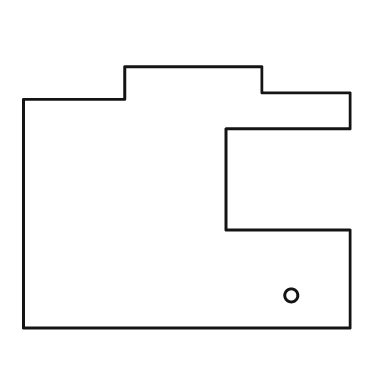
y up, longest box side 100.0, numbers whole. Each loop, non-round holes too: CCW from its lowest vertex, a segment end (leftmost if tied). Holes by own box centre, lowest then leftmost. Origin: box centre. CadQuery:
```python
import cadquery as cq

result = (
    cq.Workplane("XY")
    .moveTo(-50.0, -40.0)
    .lineTo(50.0, -40.0)
    .lineTo(50.0, -10.0)
    .lineTo(12.0, -10.0)
    .lineTo(12.0, 21.0)
    .lineTo(50.0, 21.0)
    .lineTo(50.0, 32.0)
    .lineTo(23.0, 32.0)
    .lineTo(23.0, 40.0)
    .lineTo(-19.0, 40.0)
    .lineTo(-19.0, 30.0)
    .lineTo(-50.0, 30.0)
    .close()
    .moveTo(32.0, -30.0)
    .circle(2.0)
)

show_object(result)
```